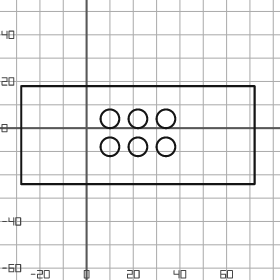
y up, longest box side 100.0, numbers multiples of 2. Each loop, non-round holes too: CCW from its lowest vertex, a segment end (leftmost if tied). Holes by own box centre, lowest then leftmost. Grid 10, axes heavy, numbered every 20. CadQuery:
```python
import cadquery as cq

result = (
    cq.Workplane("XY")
    .moveTo(-28.0, -24.0)
    .lineTo(72.0, -24.0)
    .lineTo(72.0, 18.0)
    .lineTo(-28.0, 18.0)
    .close()
    .moveTo(10.0, -8.0)
    .circle(4.0)
    .moveTo(22.0, -8.0)
    .circle(4.0)
    .moveTo(34.0, -8.0)
    .circle(4.0)
    .moveTo(10.0, 4.0)
    .circle(4.0)
    .moveTo(22.0, 4.0)
    .circle(4.0)
    .moveTo(34.0, 4.0)
    .circle(4.0)
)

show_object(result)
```